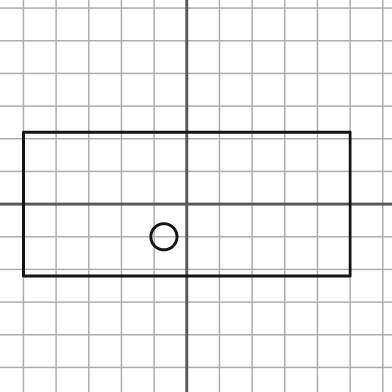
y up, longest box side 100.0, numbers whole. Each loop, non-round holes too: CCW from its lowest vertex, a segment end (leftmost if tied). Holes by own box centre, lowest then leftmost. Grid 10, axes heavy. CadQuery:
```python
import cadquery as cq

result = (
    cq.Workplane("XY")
    .moveTo(-50.0, -22.0)
    .lineTo(50.0, -22.0)
    .lineTo(50.0, 22.0)
    .lineTo(-50.0, 22.0)
    .close()
    .moveTo(-7.0, -10.0)
    .circle(4.0)
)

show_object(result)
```